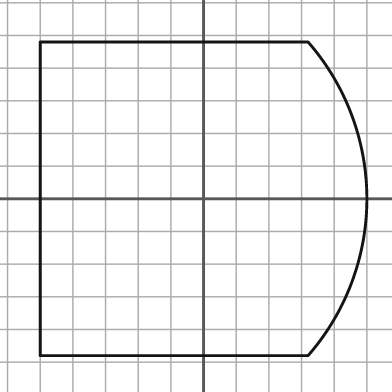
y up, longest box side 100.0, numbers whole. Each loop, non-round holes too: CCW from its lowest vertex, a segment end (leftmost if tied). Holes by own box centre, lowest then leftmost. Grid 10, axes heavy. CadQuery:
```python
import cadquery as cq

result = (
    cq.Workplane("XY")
    .moveTo(-50.0, -48.0)
    .lineTo(32.0, -48.0)
    .threePointArc((50.0, 0.0), (32.0, 48.0))
    .lineTo(-50.0, 48.0)
    .close()
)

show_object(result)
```